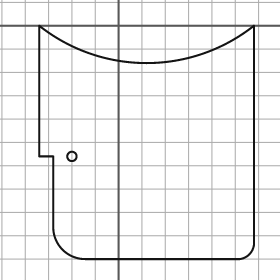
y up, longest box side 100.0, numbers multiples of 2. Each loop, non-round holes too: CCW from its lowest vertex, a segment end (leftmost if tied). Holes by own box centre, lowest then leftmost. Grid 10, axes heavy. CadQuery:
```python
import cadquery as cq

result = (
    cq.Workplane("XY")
    .moveTo(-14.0, -100.0)
    .lineTo(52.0, -100.0)
    .threePointArc((56.0, -98.0), (58.0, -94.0))
    .lineTo(58.0, 0.0)
    .threePointArc((12.0, -16.0), (-34.0, 0.0))
    .lineTo(-34.0, -56.0)
    .lineTo(-28.0, -56.0)
    .lineTo(-28.0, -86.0)
    .threePointArc((-24.0, -96.0), (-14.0, -100.0))
    .close()
    .moveTo(-20.0, -56.0)
    .circle(2.0)
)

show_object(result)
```